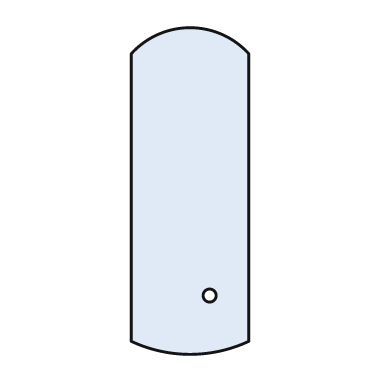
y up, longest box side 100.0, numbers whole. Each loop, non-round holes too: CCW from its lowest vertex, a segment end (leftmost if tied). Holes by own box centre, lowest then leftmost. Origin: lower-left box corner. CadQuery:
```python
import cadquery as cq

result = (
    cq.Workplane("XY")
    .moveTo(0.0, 4.0)
    .threePointArc((18.0, 0.0), (36.0, 4.0))
    .lineTo(36.0, 92.0)
    .threePointArc((18.0, 100.0), (0.0, 92.0))
    .close()
    .moveTo(24.0, 18.0)
    .circle(2.0)
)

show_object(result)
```